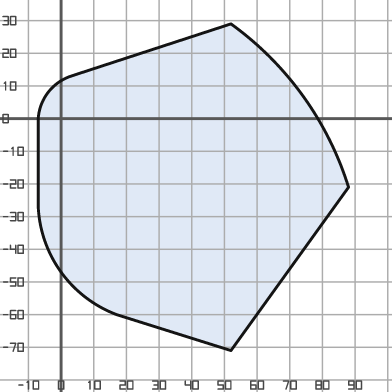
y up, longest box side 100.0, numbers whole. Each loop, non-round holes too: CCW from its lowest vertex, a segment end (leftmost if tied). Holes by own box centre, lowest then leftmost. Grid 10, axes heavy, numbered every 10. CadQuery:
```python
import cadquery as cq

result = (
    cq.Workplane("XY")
    .moveTo(52.0, -71.0)
    .lineTo(88.0, -21.0)
    .threePointArc((74.0, 7.0), (52.0, 29.0))
    .lineTo(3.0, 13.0)
    .threePointArc((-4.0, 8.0), (-7.0, 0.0))
    .lineTo(-7.0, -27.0)
    .threePointArc((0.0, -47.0), (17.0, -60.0))
    .close()
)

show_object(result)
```